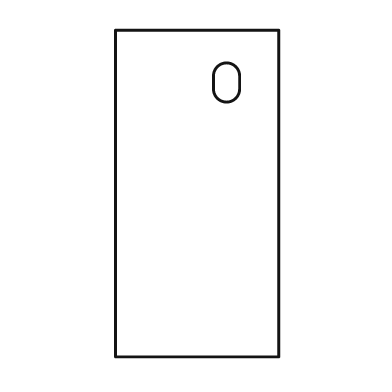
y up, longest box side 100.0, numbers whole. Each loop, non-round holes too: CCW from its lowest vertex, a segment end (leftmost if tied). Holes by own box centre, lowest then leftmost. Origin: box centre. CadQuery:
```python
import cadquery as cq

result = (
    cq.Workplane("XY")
    .moveTo(-25.0, -50.0)
    .lineTo(25.0, -50.0)
    .lineTo(25.0, 50.0)
    .lineTo(-25.0, 50.0)
    .close()
    .moveTo(5.0, 32.0)
    .threePointArc((9.0, 28.0), (13.0, 32.0))
    .lineTo(13.0, 36.0)
    .threePointArc((9.0, 40.0), (5.0, 36.0))
    .close()
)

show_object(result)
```